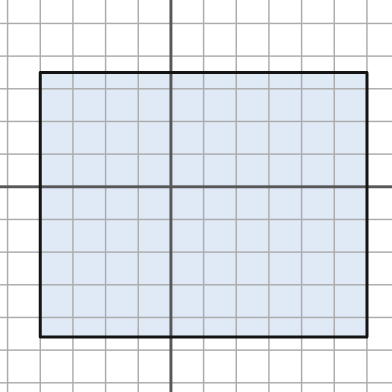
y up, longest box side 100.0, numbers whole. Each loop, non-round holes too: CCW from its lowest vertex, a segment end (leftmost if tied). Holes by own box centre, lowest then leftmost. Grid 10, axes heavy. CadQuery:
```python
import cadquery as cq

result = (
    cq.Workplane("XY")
    .moveTo(-40.0, -46.0)
    .lineTo(60.0, -46.0)
    .lineTo(60.0, 35.0)
    .lineTo(-40.0, 35.0)
    .close()
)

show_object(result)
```